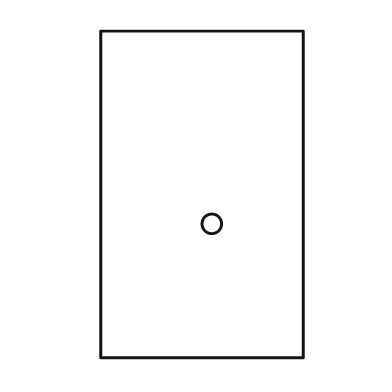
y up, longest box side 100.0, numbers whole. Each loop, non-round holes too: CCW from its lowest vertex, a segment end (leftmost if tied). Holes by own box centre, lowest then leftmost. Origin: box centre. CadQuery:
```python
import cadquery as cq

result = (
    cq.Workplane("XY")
    .moveTo(-31.0, -50.0)
    .lineTo(31.0, -50.0)
    .lineTo(31.0, 50.0)
    .lineTo(-31.0, 50.0)
    .close()
    .moveTo(3.0, -9.0)
    .circle(3.0)
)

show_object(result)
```